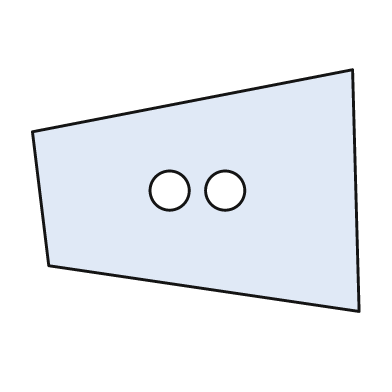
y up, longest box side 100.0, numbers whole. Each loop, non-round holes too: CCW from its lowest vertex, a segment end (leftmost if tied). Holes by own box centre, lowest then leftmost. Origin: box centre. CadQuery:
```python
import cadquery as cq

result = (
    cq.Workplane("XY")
    .moveTo(50.0, -37.0)
    .lineTo(48.0, 37.0)
    .lineTo(-50.0, 18.0)
    .lineTo(-45.0, -23.0)
    .close()
    .moveTo(-8.0, 0.0)
    .circle(6.0)
    .moveTo(9.0, 0.0)
    .circle(6.0)
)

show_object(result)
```